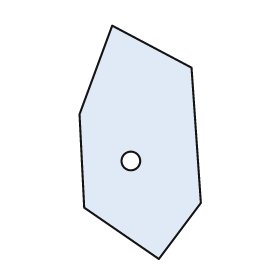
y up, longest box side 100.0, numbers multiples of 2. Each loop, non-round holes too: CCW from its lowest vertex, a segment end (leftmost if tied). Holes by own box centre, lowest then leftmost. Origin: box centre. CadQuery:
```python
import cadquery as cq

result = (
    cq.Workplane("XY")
    .moveTo(8.0, -50.0)
    .lineTo(26.0, -26.0)
    .lineTo(22.0, 32.0)
    .lineTo(-12.0, 50.0)
    .lineTo(-26.0, 12.0)
    .lineTo(-24.0, -28.0)
    .close()
    .moveTo(-4.0, -8.0)
    .circle(4.0)
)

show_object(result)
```